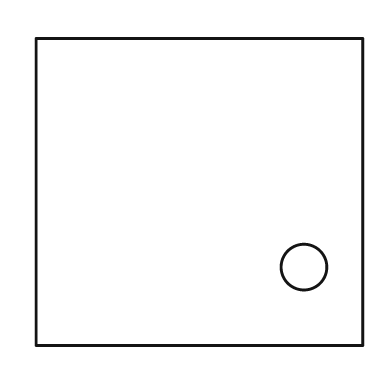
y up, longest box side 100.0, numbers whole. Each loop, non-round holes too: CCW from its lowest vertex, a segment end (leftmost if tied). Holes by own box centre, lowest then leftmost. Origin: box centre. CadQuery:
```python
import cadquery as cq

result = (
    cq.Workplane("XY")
    .moveTo(-50.0, -47.0)
    .lineTo(50.0, -47.0)
    .lineTo(50.0, 47.0)
    .lineTo(-50.0, 47.0)
    .close()
    .moveTo(32.0, -23.0)
    .circle(7.0)
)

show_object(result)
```